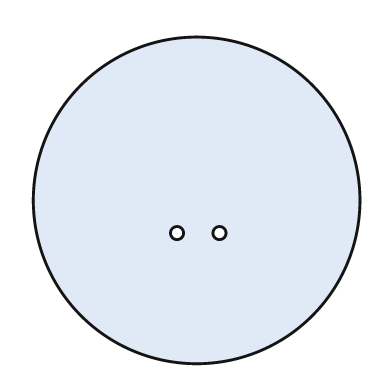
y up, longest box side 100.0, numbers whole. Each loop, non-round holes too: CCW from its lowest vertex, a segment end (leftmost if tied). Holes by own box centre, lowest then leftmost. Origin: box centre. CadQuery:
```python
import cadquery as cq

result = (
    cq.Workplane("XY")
    .moveTo(0.0, 0.0)
    .circle(50.0)
    .moveTo(-6.0, -10.0)
    .circle(2.0)
    .moveTo(7.0, -10.0)
    .circle(2.0)
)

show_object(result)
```